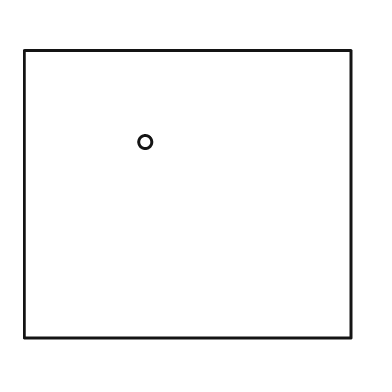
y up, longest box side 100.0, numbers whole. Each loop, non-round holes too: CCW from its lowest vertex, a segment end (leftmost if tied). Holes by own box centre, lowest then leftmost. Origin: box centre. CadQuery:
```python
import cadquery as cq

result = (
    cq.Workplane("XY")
    .moveTo(-50.0, -44.0)
    .lineTo(50.0, -44.0)
    .lineTo(50.0, 44.0)
    .lineTo(-50.0, 44.0)
    .close()
    .moveTo(-13.0, 16.0)
    .circle(2.0)
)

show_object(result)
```